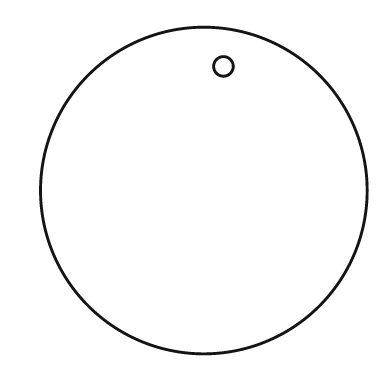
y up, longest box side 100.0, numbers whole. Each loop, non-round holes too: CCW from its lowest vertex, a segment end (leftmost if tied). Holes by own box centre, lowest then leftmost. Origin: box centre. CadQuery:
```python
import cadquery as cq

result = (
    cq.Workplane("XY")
    .moveTo(0.0, 0.0)
    .circle(50.0)
    .moveTo(6.0, 38.0)
    .circle(3.0)
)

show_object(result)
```